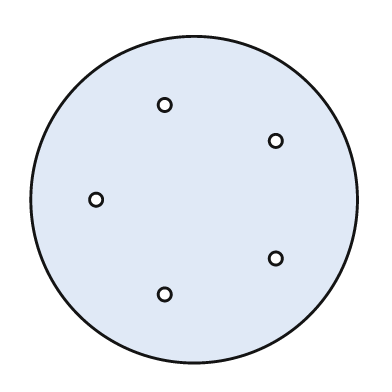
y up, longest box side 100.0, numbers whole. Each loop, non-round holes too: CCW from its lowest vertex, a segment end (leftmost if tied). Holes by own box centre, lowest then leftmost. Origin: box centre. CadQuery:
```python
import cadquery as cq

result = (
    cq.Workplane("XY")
    .moveTo(0.0, 0.0)
    .circle(50.0)
    .moveTo(-9.0, -29.0)
    .circle(2.0)
    .moveTo(25.0, -18.0)
    .circle(2.0)
    .moveTo(-30.0, 0.0)
    .circle(2.0)
    .moveTo(25.0, 18.0)
    .circle(2.0)
    .moveTo(-9.0, 29.0)
    .circle(2.0)
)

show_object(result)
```